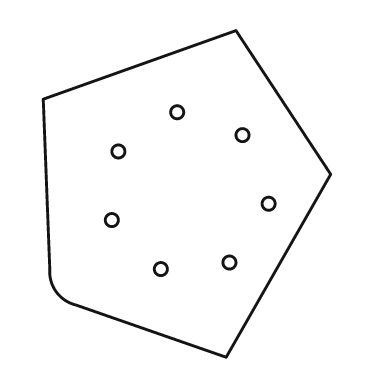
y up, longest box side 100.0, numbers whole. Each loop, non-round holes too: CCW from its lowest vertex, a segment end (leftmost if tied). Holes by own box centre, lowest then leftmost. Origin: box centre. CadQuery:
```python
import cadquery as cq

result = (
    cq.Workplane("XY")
    .moveTo(12.0, -50.0)
    .lineTo(44.0, 6.0)
    .lineTo(15.0, 50.0)
    .lineTo(-44.0, 29.0)
    .lineTo(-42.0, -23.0)
    .threePointArc((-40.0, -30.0), (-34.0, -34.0))
    .close()
    .moveTo(-8.0, -23.0)
    .circle(2.0)
    .moveTo(13.0, -21.0)
    .circle(2.0)
    .moveTo(-23.0, -8.0)
    .circle(2.0)
    .moveTo(25.0, -3.0)
    .circle(2.0)
    .moveTo(-21.0, 13.0)
    .circle(2.0)
    .moveTo(17.0, 18.0)
    .circle(2.0)
    .moveTo(-3.0, 25.0)
    .circle(2.0)
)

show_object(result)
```